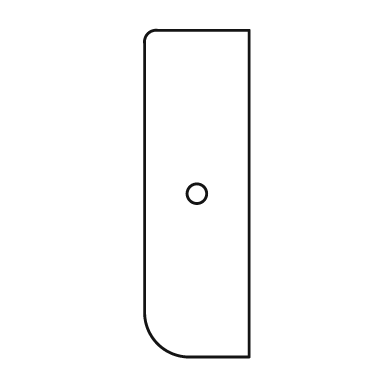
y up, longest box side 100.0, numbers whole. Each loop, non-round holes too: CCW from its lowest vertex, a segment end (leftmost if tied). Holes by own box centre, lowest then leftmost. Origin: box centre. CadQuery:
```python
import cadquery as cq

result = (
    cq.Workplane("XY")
    .moveTo(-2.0, -50.0)
    .lineTo(16.0, -50.0)
    .lineTo(16.0, 50.0)
    .lineTo(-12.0, 50.0)
    .threePointArc((-15.0, 49.0), (-16.0, 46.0))
    .lineTo(-16.0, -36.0)
    .threePointArc((-12.0, -46.0), (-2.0, -50.0))
    .close()
    .moveTo(0.0, 0.0)
    .circle(3.0)
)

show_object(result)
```